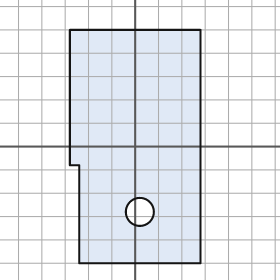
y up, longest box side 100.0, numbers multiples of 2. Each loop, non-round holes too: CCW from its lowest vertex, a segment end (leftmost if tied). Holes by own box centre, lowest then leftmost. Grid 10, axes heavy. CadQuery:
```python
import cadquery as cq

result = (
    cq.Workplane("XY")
    .moveTo(-24.0, -50.0)
    .lineTo(28.0, -50.0)
    .lineTo(28.0, 50.0)
    .lineTo(-28.0, 50.0)
    .lineTo(-28.0, -8.0)
    .lineTo(-24.0, -8.0)
    .close()
    .moveTo(2.0, -28.0)
    .circle(6.0)
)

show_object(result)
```